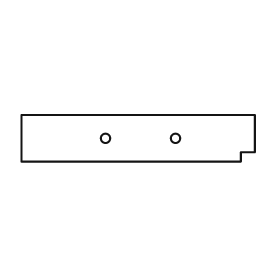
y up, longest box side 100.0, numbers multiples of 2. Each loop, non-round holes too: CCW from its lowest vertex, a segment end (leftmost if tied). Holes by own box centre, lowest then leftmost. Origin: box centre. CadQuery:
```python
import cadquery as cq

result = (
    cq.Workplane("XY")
    .moveTo(-50.0, -10.0)
    .lineTo(44.0, -10.0)
    .lineTo(44.0, -6.0)
    .lineTo(50.0, -6.0)
    .lineTo(50.0, 10.0)
    .lineTo(-50.0, 10.0)
    .close()
    .moveTo(-14.0, 0.0)
    .circle(2.0)
    .moveTo(16.0, 0.0)
    .circle(2.0)
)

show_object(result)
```